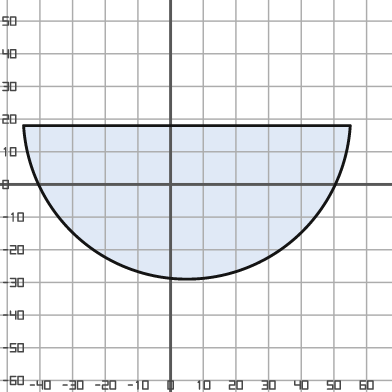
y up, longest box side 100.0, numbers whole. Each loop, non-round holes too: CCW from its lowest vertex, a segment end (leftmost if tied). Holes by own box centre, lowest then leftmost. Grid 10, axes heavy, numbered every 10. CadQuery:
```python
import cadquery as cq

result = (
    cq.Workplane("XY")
    .moveTo(-45.0, 18.0)
    .threePointArc((5.0, -29.0), (55.0, 18.0))
    .close()
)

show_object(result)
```